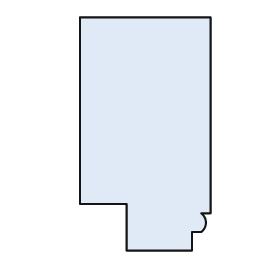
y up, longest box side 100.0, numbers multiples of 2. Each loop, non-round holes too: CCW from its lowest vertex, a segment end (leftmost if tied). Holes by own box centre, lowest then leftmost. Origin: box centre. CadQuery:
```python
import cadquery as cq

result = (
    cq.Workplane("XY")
    .moveTo(-8.0, -50.0)
    .lineTo(20.0, -50.0)
    .lineTo(20.0, -42.0)
    .lineTo(24.0, -42.0)
    .threePointArc((26.0, -38.0), (24.0, -34.0))
    .lineTo(28.0, -34.0)
    .lineTo(28.0, 50.0)
    .lineTo(-28.0, 50.0)
    .lineTo(-28.0, -30.0)
    .lineTo(-8.0, -30.0)
    .close()
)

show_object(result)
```